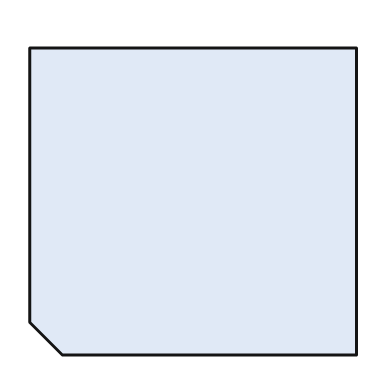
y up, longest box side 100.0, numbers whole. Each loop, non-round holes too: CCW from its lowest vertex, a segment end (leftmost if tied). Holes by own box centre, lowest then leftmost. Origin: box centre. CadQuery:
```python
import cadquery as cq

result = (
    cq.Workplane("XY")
    .moveTo(-40.0, -47.0)
    .lineTo(50.0, -47.0)
    .lineTo(50.0, 47.0)
    .lineTo(-50.0, 47.0)
    .lineTo(-50.0, -37.0)
    .close()
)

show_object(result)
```